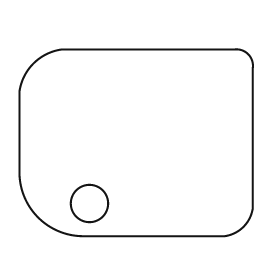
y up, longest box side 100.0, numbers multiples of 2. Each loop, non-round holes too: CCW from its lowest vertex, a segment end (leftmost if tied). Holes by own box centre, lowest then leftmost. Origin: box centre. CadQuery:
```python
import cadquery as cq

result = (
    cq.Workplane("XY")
    .moveTo(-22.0, -40.0)
    .lineTo(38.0, -40.0)
    .threePointArc((46.0, -36.0), (50.0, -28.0))
    .lineTo(50.0, 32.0)
    .threePointArc((48.0, 38.0), (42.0, 40.0))
    .lineTo(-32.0, 40.0)
    .threePointArc((-44.0, 34.0), (-50.0, 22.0))
    .lineTo(-50.0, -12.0)
    .threePointArc((-42.0, -32.0), (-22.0, -40.0))
    .close()
    .moveTo(-20.0, -26.0)
    .circle(8.0)
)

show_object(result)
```